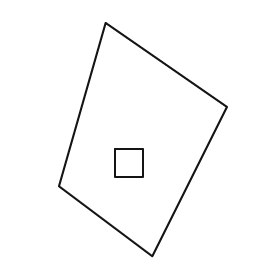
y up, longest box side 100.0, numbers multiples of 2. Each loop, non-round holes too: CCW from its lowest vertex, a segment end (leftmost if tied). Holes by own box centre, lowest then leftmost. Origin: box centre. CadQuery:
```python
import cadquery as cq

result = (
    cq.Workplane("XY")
    .moveTo(4.0, -50.0)
    .lineTo(36.0, 14.0)
    .lineTo(-16.0, 50.0)
    .lineTo(-36.0, -20.0)
    .close()
    .moveTo(-12.0, -16.0)
    .lineTo(0.0, -16.0)
    .lineTo(0.0, -4.0)
    .lineTo(-12.0, -4.0)
    .close()
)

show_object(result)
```